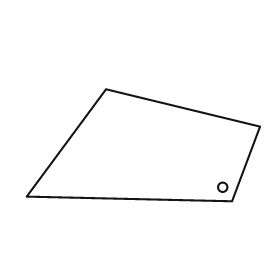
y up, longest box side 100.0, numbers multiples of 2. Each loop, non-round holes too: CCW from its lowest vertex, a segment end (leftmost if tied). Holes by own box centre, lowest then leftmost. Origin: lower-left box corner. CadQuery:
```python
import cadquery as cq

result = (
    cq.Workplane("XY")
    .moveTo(88.0, 0.0)
    .lineTo(100.0, 32.0)
    .lineTo(34.0, 48.0)
    .lineTo(0.0, 2.0)
    .close()
    .moveTo(84.0, 6.0)
    .circle(2.0)
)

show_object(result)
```